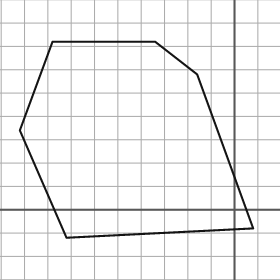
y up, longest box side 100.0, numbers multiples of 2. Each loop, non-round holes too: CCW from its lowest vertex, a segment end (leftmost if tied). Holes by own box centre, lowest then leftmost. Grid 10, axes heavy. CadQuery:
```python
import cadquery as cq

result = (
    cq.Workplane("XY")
    .moveTo(-72.0, -12.0)
    .lineTo(8.0, -8.0)
    .lineTo(-16.0, 58.0)
    .lineTo(-34.0, 72.0)
    .lineTo(-78.0, 72.0)
    .lineTo(-92.0, 34.0)
    .close()
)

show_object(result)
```